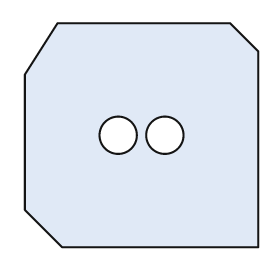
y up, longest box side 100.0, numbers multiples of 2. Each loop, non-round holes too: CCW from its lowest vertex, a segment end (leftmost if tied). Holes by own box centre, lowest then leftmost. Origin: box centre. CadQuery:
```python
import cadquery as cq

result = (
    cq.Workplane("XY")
    .moveTo(-34.0, -48.0)
    .lineTo(50.0, -48.0)
    .lineTo(50.0, 36.0)
    .lineTo(38.0, 48.0)
    .lineTo(-36.0, 48.0)
    .lineTo(-50.0, 26.0)
    .lineTo(-50.0, -32.0)
    .close()
    .moveTo(-10.0, 0.0)
    .circle(8.0)
    .moveTo(10.0, 0.0)
    .circle(8.0)
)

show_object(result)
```